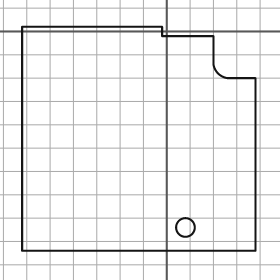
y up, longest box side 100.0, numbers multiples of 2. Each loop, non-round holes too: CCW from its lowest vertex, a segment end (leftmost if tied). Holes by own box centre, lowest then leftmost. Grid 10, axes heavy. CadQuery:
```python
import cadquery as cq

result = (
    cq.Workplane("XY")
    .moveTo(-62.0, -94.0)
    .lineTo(38.0, -94.0)
    .lineTo(38.0, -20.0)
    .lineTo(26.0, -20.0)
    .threePointArc((22.0, -18.0), (20.0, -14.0))
    .lineTo(20.0, -2.0)
    .lineTo(-2.0, -2.0)
    .lineTo(-2.0, 2.0)
    .lineTo(-62.0, 2.0)
    .close()
    .moveTo(8.0, -84.0)
    .circle(4.0)
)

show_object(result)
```